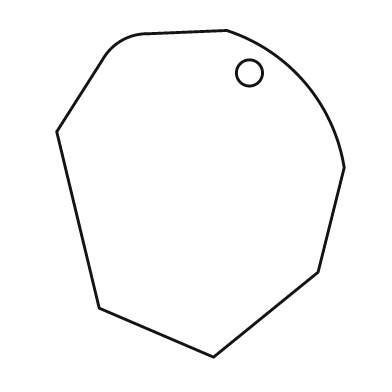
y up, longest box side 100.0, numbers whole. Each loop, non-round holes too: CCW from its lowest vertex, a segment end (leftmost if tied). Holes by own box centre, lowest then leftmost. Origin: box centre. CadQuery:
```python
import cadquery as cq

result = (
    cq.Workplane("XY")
    .moveTo(4.0, -50.0)
    .lineTo(36.0, -24.0)
    .lineTo(44.0, 8.0)
    .threePointArc((32.0, 34.0), (8.0, 50.0))
    .lineTo(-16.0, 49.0)
    .threePointArc((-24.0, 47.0), (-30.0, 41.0))
    .lineTo(-44.0, 19.0)
    .lineTo(-31.0, -35.0)
    .close()
    .moveTo(15.0, 37.0)
    .circle(4.0)
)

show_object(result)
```